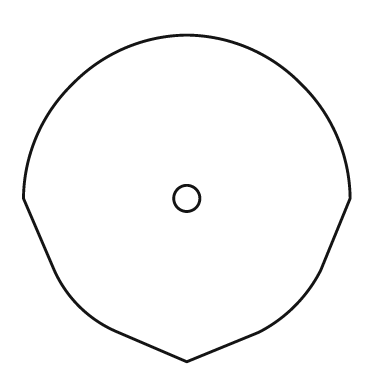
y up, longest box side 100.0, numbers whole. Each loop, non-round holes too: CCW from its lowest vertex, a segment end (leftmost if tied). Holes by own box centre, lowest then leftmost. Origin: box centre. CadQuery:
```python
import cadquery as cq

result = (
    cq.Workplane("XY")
    .moveTo(0.0, -50.0)
    .lineTo(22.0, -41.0)
    .threePointArc((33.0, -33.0), (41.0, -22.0))
    .lineTo(50.0, 0.0)
    .threePointArc((46.0, 19.0), (35.0, 35.0))
    .threePointArc((19.0, 46.0), (0.0, 50.0))
    .threePointArc((-19.0, 46.0), (-35.0, 35.0))
    .threePointArc((-46.0, 19.0), (-50.0, 0.0))
    .lineTo(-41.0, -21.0)
    .threePointArc((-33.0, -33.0), (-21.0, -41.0))
    .close()
    .moveTo(0.0, 0.0)
    .circle(4.0)
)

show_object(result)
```